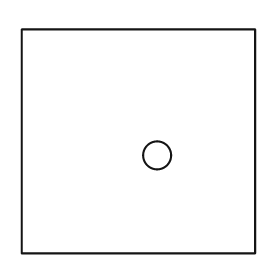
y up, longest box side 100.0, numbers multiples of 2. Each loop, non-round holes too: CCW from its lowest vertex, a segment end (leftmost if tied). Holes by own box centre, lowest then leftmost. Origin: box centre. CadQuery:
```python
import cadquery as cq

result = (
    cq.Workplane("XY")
    .moveTo(-50.0, -48.0)
    .lineTo(50.0, -48.0)
    .lineTo(50.0, 48.0)
    .lineTo(-50.0, 48.0)
    .close()
    .moveTo(8.0, -6.0)
    .circle(6.0)
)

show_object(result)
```